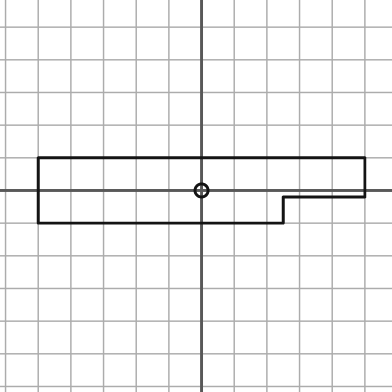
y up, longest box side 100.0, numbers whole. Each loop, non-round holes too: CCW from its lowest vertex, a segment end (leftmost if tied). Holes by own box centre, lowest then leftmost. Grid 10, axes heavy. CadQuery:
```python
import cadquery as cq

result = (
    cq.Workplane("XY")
    .moveTo(-50.0, -10.0)
    .lineTo(25.0, -10.0)
    .lineTo(25.0, -2.0)
    .lineTo(50.0, -2.0)
    .lineTo(50.0, 10.0)
    .lineTo(-50.0, 10.0)
    .close()
    .moveTo(0.0, 0.0)
    .circle(2.0)
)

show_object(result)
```